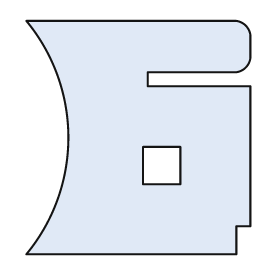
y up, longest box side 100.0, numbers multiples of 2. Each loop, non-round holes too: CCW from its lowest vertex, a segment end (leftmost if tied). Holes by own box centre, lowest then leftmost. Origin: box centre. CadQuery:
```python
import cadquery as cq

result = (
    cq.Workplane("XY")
    .moveTo(-48.0, -50.0)
    .lineTo(42.0, -50.0)
    .lineTo(42.0, -38.0)
    .lineTo(48.0, -38.0)
    .lineTo(48.0, 22.0)
    .lineTo(4.0, 22.0)
    .lineTo(4.0, 28.0)
    .lineTo(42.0, 28.0)
    .threePointArc((46.0, 30.0), (48.0, 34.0))
    .lineTo(48.0, 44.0)
    .threePointArc((46.0, 48.0), (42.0, 50.0))
    .lineTo(-48.0, 50.0)
    .threePointArc((-30.0, 0.0), (-48.0, -50.0))
    .close()
    .moveTo(2.0, -20.0)
    .lineTo(18.0, -20.0)
    .lineTo(18.0, -4.0)
    .lineTo(2.0, -4.0)
    .close()
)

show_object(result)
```